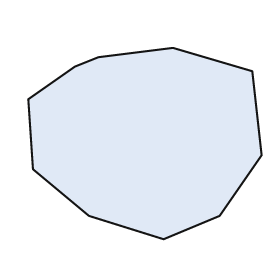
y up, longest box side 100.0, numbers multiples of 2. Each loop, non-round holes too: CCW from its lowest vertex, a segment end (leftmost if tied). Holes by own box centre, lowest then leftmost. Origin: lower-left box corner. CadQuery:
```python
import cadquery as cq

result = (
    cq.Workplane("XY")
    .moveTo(58.0, 0.0)
    .lineTo(82.0, 10.0)
    .lineTo(100.0, 36.0)
    .lineTo(96.0, 72.0)
    .lineTo(62.0, 82.0)
    .lineTo(30.0, 78.0)
    .lineTo(20.0, 74.0)
    .lineTo(0.0, 60.0)
    .lineTo(2.0, 30.0)
    .lineTo(26.0, 10.0)
    .close()
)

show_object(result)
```